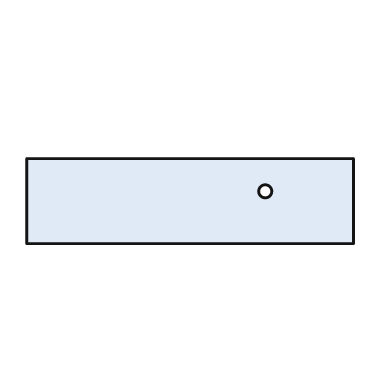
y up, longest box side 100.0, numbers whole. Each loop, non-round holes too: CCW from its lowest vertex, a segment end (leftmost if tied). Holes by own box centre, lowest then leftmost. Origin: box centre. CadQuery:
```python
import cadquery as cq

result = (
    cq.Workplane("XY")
    .moveTo(-50.0, -13.0)
    .lineTo(50.0, -13.0)
    .lineTo(50.0, 13.0)
    .lineTo(-50.0, 13.0)
    .close()
    .moveTo(23.0, 3.0)
    .circle(2.0)
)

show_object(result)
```